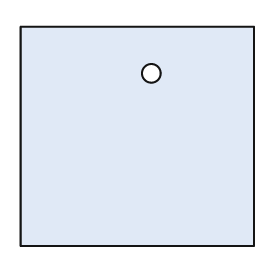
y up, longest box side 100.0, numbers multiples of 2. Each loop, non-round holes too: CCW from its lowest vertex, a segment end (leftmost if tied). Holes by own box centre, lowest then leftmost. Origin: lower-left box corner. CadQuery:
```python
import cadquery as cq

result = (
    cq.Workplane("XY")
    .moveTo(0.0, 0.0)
    .lineTo(100.0, 0.0)
    .lineTo(100.0, 94.0)
    .lineTo(0.0, 94.0)
    .close()
    .moveTo(56.0, 74.0)
    .circle(4.0)
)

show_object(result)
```